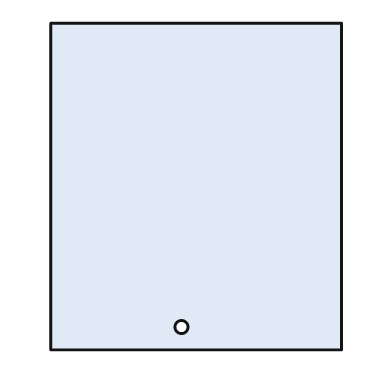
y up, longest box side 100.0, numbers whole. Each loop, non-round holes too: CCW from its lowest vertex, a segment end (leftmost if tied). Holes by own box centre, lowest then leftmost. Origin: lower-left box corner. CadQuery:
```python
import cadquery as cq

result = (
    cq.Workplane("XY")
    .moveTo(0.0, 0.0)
    .lineTo(89.0, 0.0)
    .lineTo(89.0, 100.0)
    .lineTo(0.0, 100.0)
    .close()
    .moveTo(40.0, 7.0)
    .circle(2.0)
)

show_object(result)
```